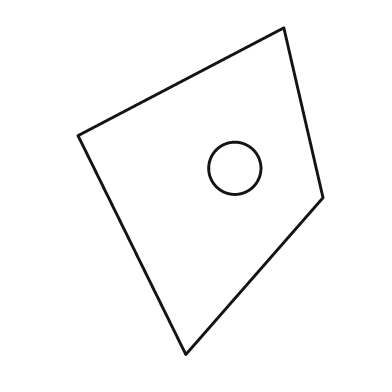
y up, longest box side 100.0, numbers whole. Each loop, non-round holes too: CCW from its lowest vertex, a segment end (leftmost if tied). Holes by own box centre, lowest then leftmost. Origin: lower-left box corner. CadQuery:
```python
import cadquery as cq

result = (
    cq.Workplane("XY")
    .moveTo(33.0, 0.0)
    .lineTo(75.0, 48.0)
    .lineTo(63.0, 100.0)
    .lineTo(0.0, 67.0)
    .close()
    .moveTo(48.0, 57.0)
    .circle(8.0)
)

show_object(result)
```